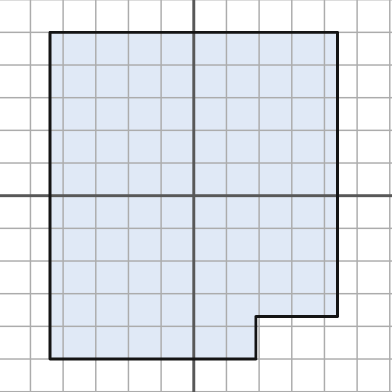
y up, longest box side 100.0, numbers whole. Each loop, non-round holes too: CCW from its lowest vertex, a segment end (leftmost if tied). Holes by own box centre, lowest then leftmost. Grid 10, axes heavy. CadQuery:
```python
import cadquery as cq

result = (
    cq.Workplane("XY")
    .moveTo(-44.0, -50.0)
    .lineTo(19.0, -50.0)
    .lineTo(19.0, -37.0)
    .lineTo(44.0, -37.0)
    .lineTo(44.0, 50.0)
    .lineTo(-44.0, 50.0)
    .close()
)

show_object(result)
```